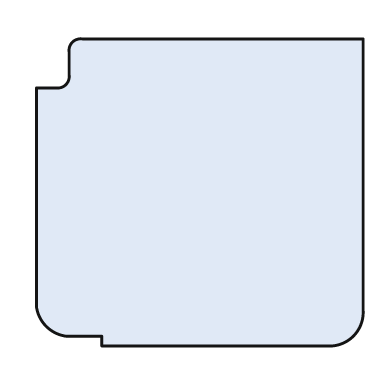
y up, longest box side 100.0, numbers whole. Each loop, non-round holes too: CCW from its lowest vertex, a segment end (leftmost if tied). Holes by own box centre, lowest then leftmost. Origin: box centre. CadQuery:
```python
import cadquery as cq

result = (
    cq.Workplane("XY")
    .moveTo(-30.0, -47.0)
    .lineTo(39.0, -47.0)
    .threePointArc((47.0, -44.0), (50.0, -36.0))
    .lineTo(50.0, 47.0)
    .lineTo(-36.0, 47.0)
    .threePointArc((-39.0, 46.0), (-40.0, 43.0))
    .lineTo(-40.0, 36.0)
    .threePointArc((-41.0, 33.0), (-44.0, 32.0))
    .lineTo(-50.0, 32.0)
    .lineTo(-50.0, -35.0)
    .threePointArc((-47.0, -41.0), (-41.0, -44.0))
    .lineTo(-30.0, -44.0)
    .close()
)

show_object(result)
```